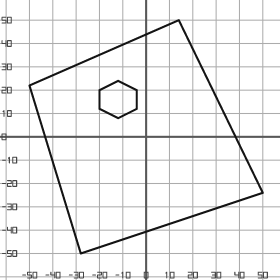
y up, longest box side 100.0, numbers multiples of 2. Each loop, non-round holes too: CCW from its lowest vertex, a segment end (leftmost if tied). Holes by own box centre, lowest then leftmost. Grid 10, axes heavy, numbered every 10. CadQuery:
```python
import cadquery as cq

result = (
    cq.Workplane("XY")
    .moveTo(-28.0, -50.0)
    .lineTo(50.0, -24.0)
    .lineTo(14.0, 50.0)
    .lineTo(-50.0, 22.0)
    .close()
    .moveTo(-12.0, 8.0)
    .lineTo(-4.0, 12.0)
    .lineTo(-4.0, 20.0)
    .lineTo(-12.0, 24.0)
    .lineTo(-20.0, 20.0)
    .lineTo(-20.0, 12.0)
    .close()
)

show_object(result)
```